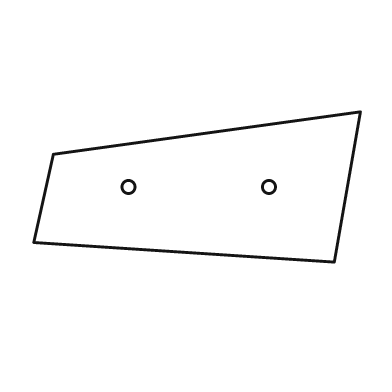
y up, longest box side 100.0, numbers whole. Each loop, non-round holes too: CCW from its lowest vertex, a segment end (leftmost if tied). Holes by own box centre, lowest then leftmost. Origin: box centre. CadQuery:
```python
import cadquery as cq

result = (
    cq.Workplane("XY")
    .moveTo(42.0, -23.0)
    .lineTo(50.0, 23.0)
    .lineTo(-44.0, 10.0)
    .lineTo(-50.0, -17.0)
    .close()
    .moveTo(-21.0, 0.0)
    .circle(2.0)
    .moveTo(22.0, 0.0)
    .circle(2.0)
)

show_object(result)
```